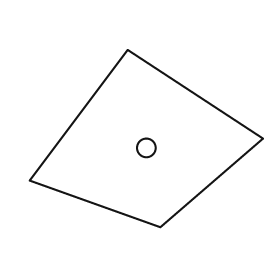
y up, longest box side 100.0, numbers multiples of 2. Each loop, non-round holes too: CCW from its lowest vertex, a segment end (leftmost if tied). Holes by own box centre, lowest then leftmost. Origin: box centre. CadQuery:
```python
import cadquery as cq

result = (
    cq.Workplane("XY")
    .moveTo(6.0, -38.0)
    .lineTo(50.0, 0.0)
    .lineTo(-8.0, 38.0)
    .lineTo(-50.0, -18.0)
    .close()
    .moveTo(0.0, -4.0)
    .circle(4.0)
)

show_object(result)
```